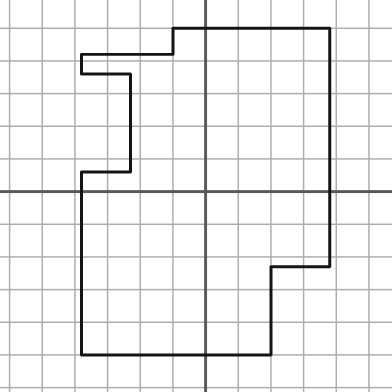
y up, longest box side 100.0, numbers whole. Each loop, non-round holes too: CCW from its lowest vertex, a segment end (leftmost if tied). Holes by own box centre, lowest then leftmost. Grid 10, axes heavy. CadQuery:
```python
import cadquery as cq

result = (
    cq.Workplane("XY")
    .moveTo(-38.0, -50.0)
    .lineTo(20.0, -50.0)
    .lineTo(20.0, -23.0)
    .lineTo(38.0, -23.0)
    .lineTo(38.0, 50.0)
    .lineTo(-10.0, 50.0)
    .lineTo(-10.0, 42.0)
    .lineTo(-38.0, 42.0)
    .lineTo(-38.0, 36.0)
    .lineTo(-23.0, 36.0)
    .lineTo(-23.0, 6.0)
    .lineTo(-38.0, 6.0)
    .close()
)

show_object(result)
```